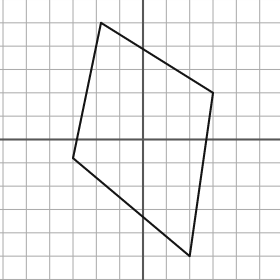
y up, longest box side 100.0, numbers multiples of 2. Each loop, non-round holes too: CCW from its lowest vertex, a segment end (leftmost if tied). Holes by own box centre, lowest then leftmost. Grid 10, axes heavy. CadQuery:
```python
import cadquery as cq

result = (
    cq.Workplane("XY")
    .moveTo(20.0, -50.0)
    .lineTo(30.0, 20.0)
    .lineTo(-18.0, 50.0)
    .lineTo(-30.0, -8.0)
    .close()
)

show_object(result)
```